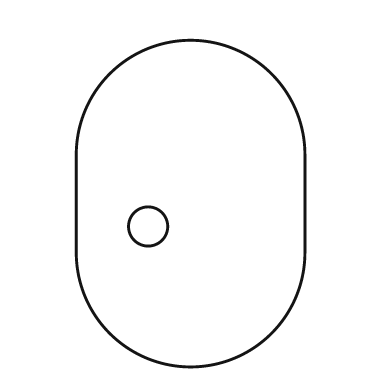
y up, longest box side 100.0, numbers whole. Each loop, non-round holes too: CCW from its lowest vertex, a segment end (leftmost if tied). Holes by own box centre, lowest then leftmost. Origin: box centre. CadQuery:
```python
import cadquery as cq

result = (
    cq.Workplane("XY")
    .moveTo(-35.0, -15.0)
    .threePointArc((0.0, -50.0), (35.0, -15.0))
    .lineTo(35.0, 15.0)
    .threePointArc((0.0, 50.0), (-35.0, 15.0))
    .close()
    .moveTo(-13.0, -7.0)
    .circle(6.0)
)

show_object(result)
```